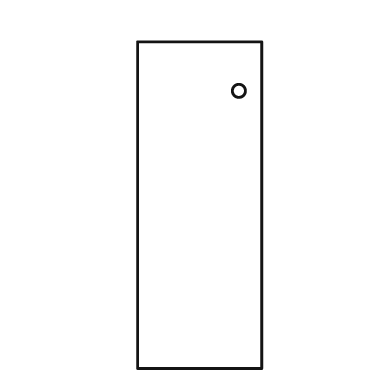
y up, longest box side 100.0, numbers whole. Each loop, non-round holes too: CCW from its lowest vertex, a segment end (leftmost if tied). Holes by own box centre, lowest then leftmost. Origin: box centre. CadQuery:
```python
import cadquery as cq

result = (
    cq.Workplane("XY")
    .moveTo(-19.0, -50.0)
    .lineTo(19.0, -50.0)
    .lineTo(19.0, 50.0)
    .lineTo(-19.0, 50.0)
    .close()
    .moveTo(12.0, 35.0)
    .circle(2.0)
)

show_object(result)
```